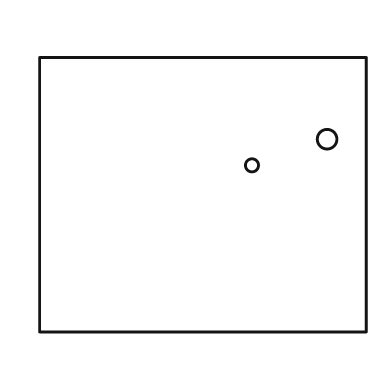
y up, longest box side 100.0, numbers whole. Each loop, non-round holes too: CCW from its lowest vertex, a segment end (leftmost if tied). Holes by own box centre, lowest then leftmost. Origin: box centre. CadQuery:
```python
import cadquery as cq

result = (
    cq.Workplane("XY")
    .moveTo(-50.0, -42.0)
    .lineTo(50.0, -42.0)
    .lineTo(50.0, 42.0)
    .lineTo(-50.0, 42.0)
    .close()
    .moveTo(15.0, 9.0)
    .circle(2.0)
    .moveTo(38.0, 17.0)
    .circle(3.0)
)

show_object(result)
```